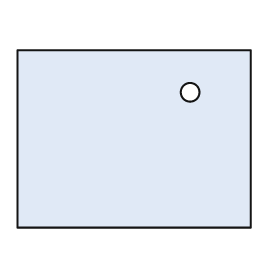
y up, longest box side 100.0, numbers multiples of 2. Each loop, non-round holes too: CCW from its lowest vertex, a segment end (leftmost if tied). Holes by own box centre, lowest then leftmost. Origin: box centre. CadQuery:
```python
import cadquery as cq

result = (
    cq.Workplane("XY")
    .moveTo(-50.0, -38.0)
    .lineTo(50.0, -38.0)
    .lineTo(50.0, 38.0)
    .lineTo(-50.0, 38.0)
    .close()
    .moveTo(24.0, 20.0)
    .circle(4.0)
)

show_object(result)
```